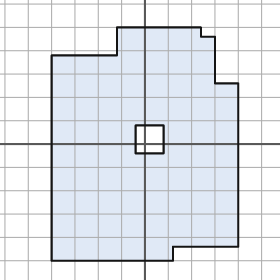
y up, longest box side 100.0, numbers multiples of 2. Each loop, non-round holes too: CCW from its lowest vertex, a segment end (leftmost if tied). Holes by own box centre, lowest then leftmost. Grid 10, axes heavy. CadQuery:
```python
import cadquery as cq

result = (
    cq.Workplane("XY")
    .moveTo(-40.0, -50.0)
    .lineTo(12.0, -50.0)
    .lineTo(12.0, -44.0)
    .lineTo(40.0, -44.0)
    .lineTo(40.0, 26.0)
    .lineTo(30.0, 26.0)
    .lineTo(30.0, 46.0)
    .lineTo(24.0, 46.0)
    .lineTo(24.0, 50.0)
    .lineTo(-12.0, 50.0)
    .lineTo(-12.0, 38.0)
    .lineTo(-40.0, 38.0)
    .close()
    .moveTo(-4.0, -4.0)
    .lineTo(8.0, -4.0)
    .lineTo(8.0, 8.0)
    .lineTo(-4.0, 8.0)
    .close()
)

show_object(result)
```